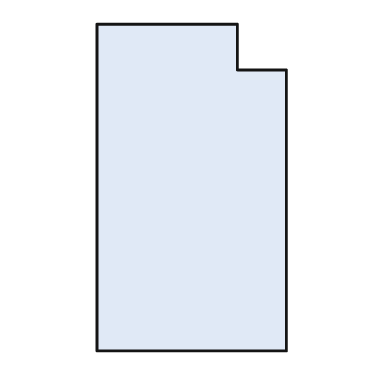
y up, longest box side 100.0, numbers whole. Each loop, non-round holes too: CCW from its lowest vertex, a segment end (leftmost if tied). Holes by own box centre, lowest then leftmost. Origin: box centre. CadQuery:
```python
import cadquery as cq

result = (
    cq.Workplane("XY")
    .moveTo(-29.0, -50.0)
    .lineTo(29.0, -50.0)
    .lineTo(29.0, 36.0)
    .lineTo(14.0, 36.0)
    .lineTo(14.0, 50.0)
    .lineTo(-29.0, 50.0)
    .close()
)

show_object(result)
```